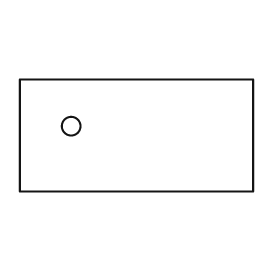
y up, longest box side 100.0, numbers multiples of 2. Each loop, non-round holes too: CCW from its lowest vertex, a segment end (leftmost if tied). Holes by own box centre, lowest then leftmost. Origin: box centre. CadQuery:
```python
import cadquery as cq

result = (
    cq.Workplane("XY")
    .moveTo(-50.0, -24.0)
    .lineTo(50.0, -24.0)
    .lineTo(50.0, 24.0)
    .lineTo(-50.0, 24.0)
    .close()
    .moveTo(-28.0, 4.0)
    .circle(4.0)
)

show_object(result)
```